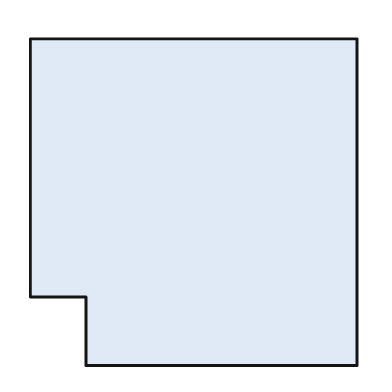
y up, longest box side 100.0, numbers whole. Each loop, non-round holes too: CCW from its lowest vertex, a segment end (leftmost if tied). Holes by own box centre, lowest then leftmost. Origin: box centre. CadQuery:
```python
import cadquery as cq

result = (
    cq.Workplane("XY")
    .moveTo(-33.0, -50.0)
    .lineTo(50.0, -50.0)
    .lineTo(50.0, 50.0)
    .lineTo(-50.0, 50.0)
    .lineTo(-50.0, -29.0)
    .lineTo(-33.0, -29.0)
    .close()
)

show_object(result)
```